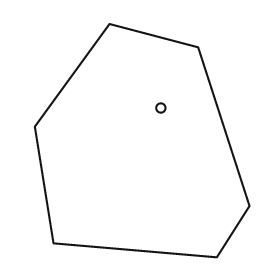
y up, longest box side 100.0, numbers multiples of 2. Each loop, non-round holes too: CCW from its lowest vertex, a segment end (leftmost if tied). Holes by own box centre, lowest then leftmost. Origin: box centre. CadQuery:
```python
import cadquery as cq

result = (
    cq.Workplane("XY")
    .moveTo(32.0, -50.0)
    .lineTo(46.0, -28.0)
    .lineTo(24.0, 40.0)
    .lineTo(-14.0, 50.0)
    .lineTo(-46.0, 6.0)
    .lineTo(-38.0, -44.0)
    .close()
    .moveTo(8.0, 14.0)
    .circle(2.0)
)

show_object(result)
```